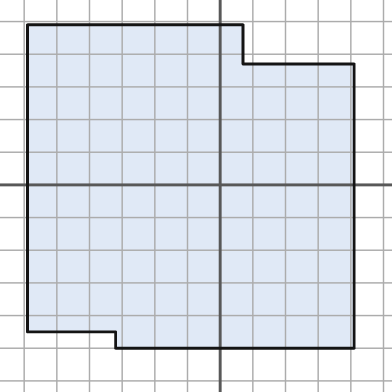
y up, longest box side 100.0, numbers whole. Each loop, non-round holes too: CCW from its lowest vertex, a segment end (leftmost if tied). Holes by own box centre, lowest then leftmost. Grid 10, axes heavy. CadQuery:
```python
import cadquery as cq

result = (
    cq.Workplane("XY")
    .moveTo(-32.0, -50.0)
    .lineTo(41.0, -50.0)
    .lineTo(41.0, 37.0)
    .lineTo(7.0, 37.0)
    .lineTo(7.0, 49.0)
    .lineTo(-59.0, 49.0)
    .lineTo(-59.0, -45.0)
    .lineTo(-32.0, -45.0)
    .close()
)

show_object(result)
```